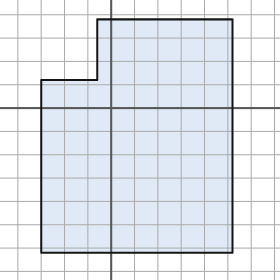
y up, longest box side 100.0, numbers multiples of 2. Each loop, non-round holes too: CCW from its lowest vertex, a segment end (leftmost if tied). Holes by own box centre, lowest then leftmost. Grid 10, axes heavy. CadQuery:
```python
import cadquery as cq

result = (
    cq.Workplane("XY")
    .moveTo(-30.0, -62.0)
    .lineTo(52.0, -62.0)
    .lineTo(52.0, 38.0)
    .lineTo(-6.0, 38.0)
    .lineTo(-6.0, 12.0)
    .lineTo(-30.0, 12.0)
    .close()
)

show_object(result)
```